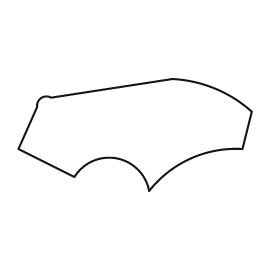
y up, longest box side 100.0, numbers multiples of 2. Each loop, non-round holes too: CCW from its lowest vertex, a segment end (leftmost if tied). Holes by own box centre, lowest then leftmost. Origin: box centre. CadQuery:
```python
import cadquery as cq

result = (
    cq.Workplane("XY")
    .moveTo(6.0, -24.0)
    .threePointArc((24.0, -10.0), (46.0, -6.0))
    .lineTo(50.0, 10.0)
    .threePointArc((34.0, 20.0), (16.0, 24.0))
    .lineTo(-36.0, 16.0)
    .threePointArc((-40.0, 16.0), (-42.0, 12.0))
    .lineTo(-50.0, -6.0)
    .lineTo(-26.0, -18.0)
    .threePointArc((-8.0, -10.0), (6.0, -24.0))
    .close()
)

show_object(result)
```